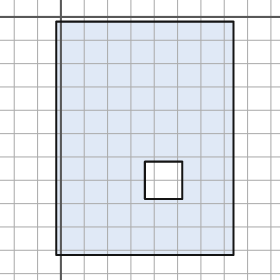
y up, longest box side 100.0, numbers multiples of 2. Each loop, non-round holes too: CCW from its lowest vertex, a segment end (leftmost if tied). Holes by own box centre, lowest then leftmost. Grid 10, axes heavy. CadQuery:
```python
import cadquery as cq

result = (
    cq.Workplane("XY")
    .moveTo(-2.0, -102.0)
    .lineTo(74.0, -102.0)
    .lineTo(74.0, -2.0)
    .lineTo(-2.0, -2.0)
    .close()
    .moveTo(36.0, -78.0)
    .lineTo(52.0, -78.0)
    .lineTo(52.0, -62.0)
    .lineTo(36.0, -62.0)
    .close()
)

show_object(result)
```